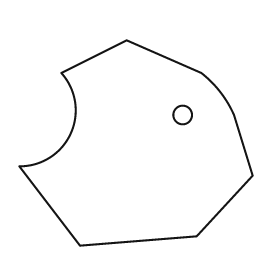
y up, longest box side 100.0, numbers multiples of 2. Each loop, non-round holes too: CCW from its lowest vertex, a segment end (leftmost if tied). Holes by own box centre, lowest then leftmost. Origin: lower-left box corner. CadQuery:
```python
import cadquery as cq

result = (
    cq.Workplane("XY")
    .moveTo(26.0, 0.0)
    .lineTo(76.0, 4.0)
    .lineTo(100.0, 30.0)
    .lineTo(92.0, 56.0)
    .threePointArc((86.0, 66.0), (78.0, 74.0))
    .lineTo(46.0, 88.0)
    .lineTo(18.0, 74.0)
    .threePointArc((22.0, 48.0), (0.0, 34.0))
    .close()
    .moveTo(70.0, 56.0)
    .circle(4.0)
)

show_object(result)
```